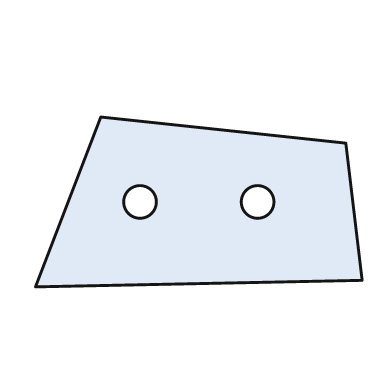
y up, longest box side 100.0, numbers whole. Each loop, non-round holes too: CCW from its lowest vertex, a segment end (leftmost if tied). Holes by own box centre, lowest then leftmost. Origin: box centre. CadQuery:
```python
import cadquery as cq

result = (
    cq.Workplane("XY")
    .moveTo(-50.0, -26.0)
    .lineTo(50.0, -24.0)
    .lineTo(45.0, 18.0)
    .lineTo(-30.0, 26.0)
    .close()
    .moveTo(-18.0, 0.0)
    .circle(5.0)
    .moveTo(18.0, 0.0)
    .circle(5.0)
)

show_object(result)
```